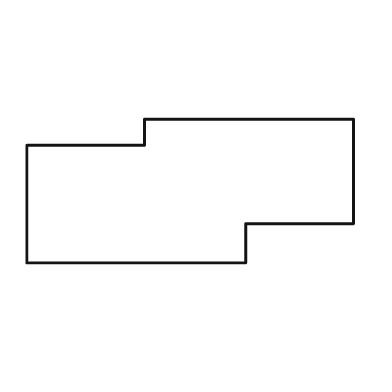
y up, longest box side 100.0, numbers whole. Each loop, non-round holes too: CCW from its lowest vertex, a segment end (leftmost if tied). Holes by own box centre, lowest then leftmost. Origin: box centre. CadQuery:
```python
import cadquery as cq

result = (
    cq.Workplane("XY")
    .moveTo(-50.0, -22.0)
    .lineTo(17.0, -22.0)
    .lineTo(17.0, -10.0)
    .lineTo(50.0, -10.0)
    .lineTo(50.0, 22.0)
    .lineTo(-14.0, 22.0)
    .lineTo(-14.0, 14.0)
    .lineTo(-50.0, 14.0)
    .close()
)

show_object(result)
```